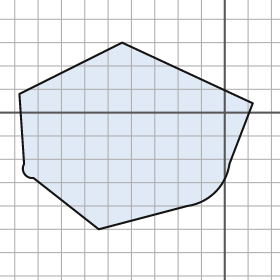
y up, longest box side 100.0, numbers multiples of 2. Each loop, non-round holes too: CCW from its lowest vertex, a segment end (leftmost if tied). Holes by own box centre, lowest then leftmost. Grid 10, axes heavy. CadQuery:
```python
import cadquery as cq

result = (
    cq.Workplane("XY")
    .moveTo(-54.0, -50.0)
    .lineTo(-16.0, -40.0)
    .threePointArc((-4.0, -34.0), (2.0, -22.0))
    .lineTo(12.0, 4.0)
    .lineTo(-44.0, 30.0)
    .lineTo(-88.0, 8.0)
    .lineTo(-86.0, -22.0)
    .threePointArc((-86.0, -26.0), (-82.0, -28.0))
    .close()
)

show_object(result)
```